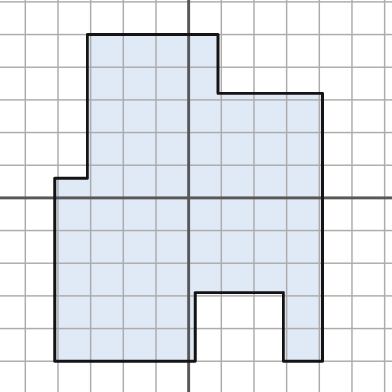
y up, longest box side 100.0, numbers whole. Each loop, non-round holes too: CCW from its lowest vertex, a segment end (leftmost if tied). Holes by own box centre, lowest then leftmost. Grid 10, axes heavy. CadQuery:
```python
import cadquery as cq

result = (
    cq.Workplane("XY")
    .moveTo(-41.0, -50.0)
    .lineTo(2.0, -50.0)
    .lineTo(2.0, -29.0)
    .lineTo(29.0, -29.0)
    .lineTo(29.0, -50.0)
    .lineTo(41.0, -50.0)
    .lineTo(41.0, 32.0)
    .lineTo(9.0, 32.0)
    .lineTo(9.0, 50.0)
    .lineTo(-31.0, 50.0)
    .lineTo(-31.0, 6.0)
    .lineTo(-41.0, 6.0)
    .close()
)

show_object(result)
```